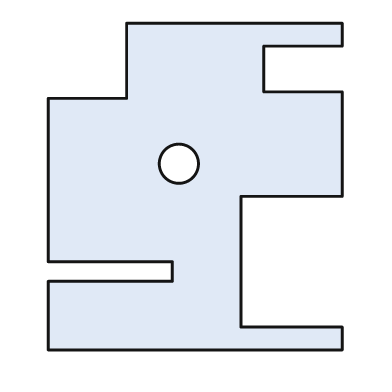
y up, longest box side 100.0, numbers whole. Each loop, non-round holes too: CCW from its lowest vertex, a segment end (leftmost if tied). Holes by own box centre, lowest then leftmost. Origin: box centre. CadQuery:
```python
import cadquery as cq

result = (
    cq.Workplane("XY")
    .moveTo(-45.0, -50.0)
    .lineTo(45.0, -50.0)
    .lineTo(45.0, -43.0)
    .lineTo(14.0, -43.0)
    .lineTo(14.0, -3.0)
    .lineTo(45.0, -3.0)
    .lineTo(45.0, 29.0)
    .lineTo(21.0, 29.0)
    .lineTo(21.0, 43.0)
    .lineTo(45.0, 43.0)
    .lineTo(45.0, 50.0)
    .lineTo(-21.0, 50.0)
    .lineTo(-21.0, 27.0)
    .lineTo(-45.0, 27.0)
    .lineTo(-45.0, -23.0)
    .lineTo(-7.0, -23.0)
    .lineTo(-7.0, -29.0)
    .lineTo(-45.0, -29.0)
    .close()
    .moveTo(-5.0, 7.0)
    .circle(6.0)
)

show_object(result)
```